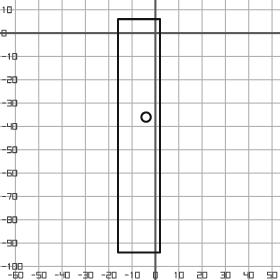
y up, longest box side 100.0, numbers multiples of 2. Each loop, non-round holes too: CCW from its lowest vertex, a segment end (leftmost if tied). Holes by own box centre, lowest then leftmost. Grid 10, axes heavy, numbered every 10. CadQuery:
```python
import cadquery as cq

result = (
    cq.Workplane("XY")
    .moveTo(-16.0, -94.0)
    .lineTo(2.0, -94.0)
    .lineTo(2.0, 6.0)
    .lineTo(-16.0, 6.0)
    .close()
    .moveTo(-4.0, -36.0)
    .circle(2.0)
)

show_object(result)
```